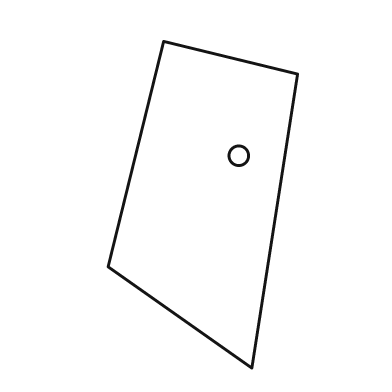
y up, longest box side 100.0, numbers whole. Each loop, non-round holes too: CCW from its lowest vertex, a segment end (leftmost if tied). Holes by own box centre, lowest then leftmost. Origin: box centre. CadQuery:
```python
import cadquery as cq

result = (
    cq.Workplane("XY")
    .moveTo(15.0, -50.0)
    .lineTo(29.0, 40.0)
    .lineTo(-12.0, 50.0)
    .lineTo(-29.0, -19.0)
    .close()
    .moveTo(11.0, 15.0)
    .circle(3.0)
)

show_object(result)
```